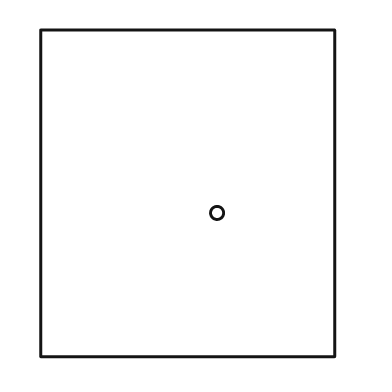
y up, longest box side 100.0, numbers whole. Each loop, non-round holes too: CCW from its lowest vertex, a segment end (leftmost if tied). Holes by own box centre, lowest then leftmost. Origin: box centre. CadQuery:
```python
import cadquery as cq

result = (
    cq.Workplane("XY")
    .moveTo(-45.0, -50.0)
    .lineTo(45.0, -50.0)
    .lineTo(45.0, 50.0)
    .lineTo(-45.0, 50.0)
    .close()
    .moveTo(9.0, -6.0)
    .circle(2.0)
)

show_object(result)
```